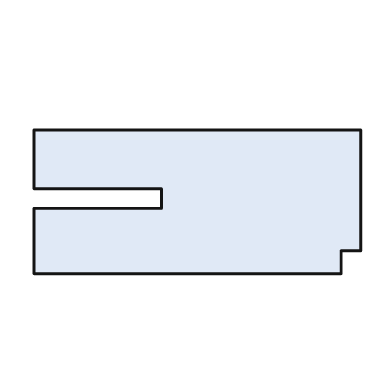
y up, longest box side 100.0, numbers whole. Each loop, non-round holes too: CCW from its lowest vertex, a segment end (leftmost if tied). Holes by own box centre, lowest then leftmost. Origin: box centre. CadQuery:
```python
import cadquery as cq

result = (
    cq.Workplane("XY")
    .moveTo(-50.0, -22.0)
    .lineTo(44.0, -22.0)
    .lineTo(44.0, -15.0)
    .lineTo(50.0, -15.0)
    .lineTo(50.0, 22.0)
    .lineTo(-50.0, 22.0)
    .lineTo(-50.0, 4.0)
    .lineTo(-11.0, 4.0)
    .lineTo(-11.0, -2.0)
    .lineTo(-50.0, -2.0)
    .close()
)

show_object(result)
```